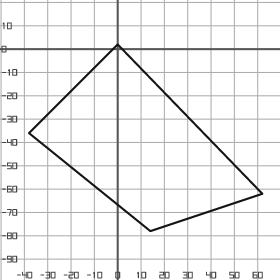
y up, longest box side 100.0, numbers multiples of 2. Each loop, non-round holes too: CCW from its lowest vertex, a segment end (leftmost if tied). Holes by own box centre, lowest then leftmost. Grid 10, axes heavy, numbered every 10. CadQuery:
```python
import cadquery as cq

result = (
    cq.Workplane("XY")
    .moveTo(14.0, -78.0)
    .lineTo(62.0, -62.0)
    .lineTo(0.0, 2.0)
    .lineTo(-38.0, -36.0)
    .close()
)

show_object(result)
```